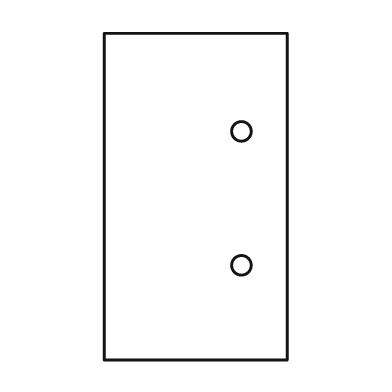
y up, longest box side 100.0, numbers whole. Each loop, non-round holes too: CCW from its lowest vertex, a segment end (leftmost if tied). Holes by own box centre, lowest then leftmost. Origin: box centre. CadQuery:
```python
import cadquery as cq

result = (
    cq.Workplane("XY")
    .moveTo(-28.0, -50.0)
    .lineTo(28.0, -50.0)
    .lineTo(28.0, 50.0)
    .lineTo(-28.0, 50.0)
    .close()
    .moveTo(14.0, -21.0)
    .circle(3.0)
    .moveTo(14.0, 20.0)
    .circle(3.0)
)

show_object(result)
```